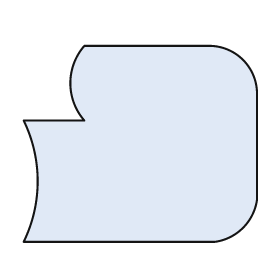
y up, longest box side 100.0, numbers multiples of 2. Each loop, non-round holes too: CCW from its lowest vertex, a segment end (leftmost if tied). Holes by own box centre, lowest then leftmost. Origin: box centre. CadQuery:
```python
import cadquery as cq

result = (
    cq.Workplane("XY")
    .moveTo(-50.0, -42.0)
    .lineTo(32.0, -42.0)
    .threePointArc((44.0, -36.0), (50.0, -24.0))
    .lineTo(50.0, 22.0)
    .threePointArc((44.0, 36.0), (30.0, 42.0))
    .lineTo(-24.0, 42.0)
    .threePointArc((-30.0, 26.0), (-24.0, 10.0))
    .lineTo(-50.0, 10.0)
    .threePointArc((-44.0, -16.0), (-50.0, -42.0))
    .close()
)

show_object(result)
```